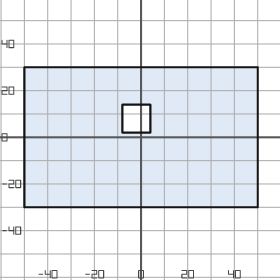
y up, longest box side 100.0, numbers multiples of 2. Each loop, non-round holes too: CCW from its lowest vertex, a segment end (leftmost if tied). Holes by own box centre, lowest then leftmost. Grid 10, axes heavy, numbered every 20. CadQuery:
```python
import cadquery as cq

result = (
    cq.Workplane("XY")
    .moveTo(-50.0, -30.0)
    .lineTo(50.0, -30.0)
    .lineTo(50.0, 30.0)
    .lineTo(-50.0, 30.0)
    .close()
    .moveTo(-8.0, 2.0)
    .lineTo(4.0, 2.0)
    .lineTo(4.0, 14.0)
    .lineTo(-8.0, 14.0)
    .close()
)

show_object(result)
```